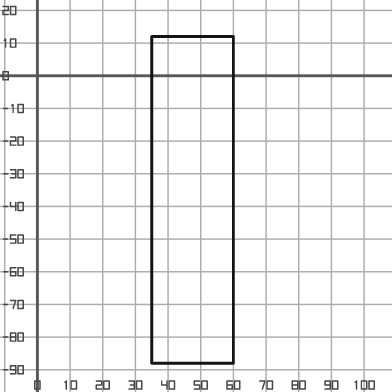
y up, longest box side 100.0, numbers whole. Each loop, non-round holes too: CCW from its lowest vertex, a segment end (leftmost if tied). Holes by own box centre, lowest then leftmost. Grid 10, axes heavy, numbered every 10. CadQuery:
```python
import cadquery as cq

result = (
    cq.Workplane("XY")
    .moveTo(35.0, -88.0)
    .lineTo(60.0, -88.0)
    .lineTo(60.0, 12.0)
    .lineTo(35.0, 12.0)
    .close()
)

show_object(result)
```